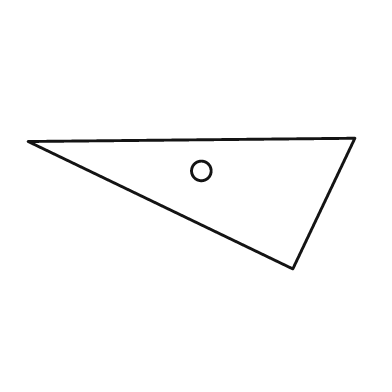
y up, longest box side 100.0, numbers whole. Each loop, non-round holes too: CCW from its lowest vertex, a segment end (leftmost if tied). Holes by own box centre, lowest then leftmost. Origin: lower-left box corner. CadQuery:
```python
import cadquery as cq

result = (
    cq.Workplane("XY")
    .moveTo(81.0, 0.0)
    .lineTo(100.0, 40.0)
    .lineTo(0.0, 39.0)
    .close()
    .moveTo(53.0, 30.0)
    .circle(3.0)
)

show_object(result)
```